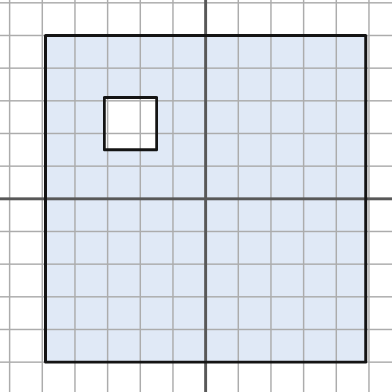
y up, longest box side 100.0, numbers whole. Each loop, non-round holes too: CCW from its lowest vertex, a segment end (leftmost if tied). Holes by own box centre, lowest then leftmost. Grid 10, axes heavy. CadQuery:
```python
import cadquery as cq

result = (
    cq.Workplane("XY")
    .moveTo(-49.0, -50.0)
    .lineTo(49.0, -50.0)
    .lineTo(49.0, 50.0)
    .lineTo(-49.0, 50.0)
    .close()
    .moveTo(-31.0, 15.0)
    .lineTo(-15.0, 15.0)
    .lineTo(-15.0, 31.0)
    .lineTo(-31.0, 31.0)
    .close()
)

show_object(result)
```